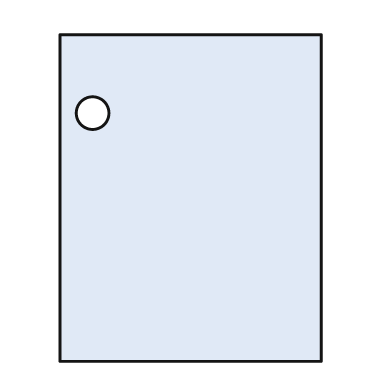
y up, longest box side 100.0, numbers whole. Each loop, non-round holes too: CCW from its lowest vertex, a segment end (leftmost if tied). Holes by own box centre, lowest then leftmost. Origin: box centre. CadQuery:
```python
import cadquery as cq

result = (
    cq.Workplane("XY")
    .moveTo(-40.0, -50.0)
    .lineTo(40.0, -50.0)
    .lineTo(40.0, 50.0)
    .lineTo(-40.0, 50.0)
    .close()
    .moveTo(-30.0, 26.0)
    .circle(5.0)
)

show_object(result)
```